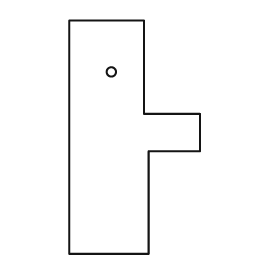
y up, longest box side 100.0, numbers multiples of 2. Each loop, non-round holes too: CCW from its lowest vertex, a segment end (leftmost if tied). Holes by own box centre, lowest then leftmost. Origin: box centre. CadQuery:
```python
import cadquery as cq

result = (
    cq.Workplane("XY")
    .moveTo(-28.0, -50.0)
    .lineTo(6.0, -50.0)
    .lineTo(6.0, -6.0)
    .lineTo(28.0, -6.0)
    .lineTo(28.0, 10.0)
    .lineTo(4.0, 10.0)
    .lineTo(4.0, 50.0)
    .lineTo(-28.0, 50.0)
    .close()
    .moveTo(-10.0, 28.0)
    .circle(2.0)
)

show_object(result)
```